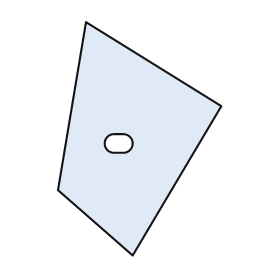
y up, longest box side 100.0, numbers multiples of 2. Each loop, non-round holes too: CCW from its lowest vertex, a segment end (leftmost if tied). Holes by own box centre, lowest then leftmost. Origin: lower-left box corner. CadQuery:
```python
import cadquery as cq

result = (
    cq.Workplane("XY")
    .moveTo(32.0, 0.0)
    .lineTo(70.0, 64.0)
    .lineTo(12.0, 100.0)
    .lineTo(0.0, 28.0)
    .close()
    .moveTo(24.0, 44.0)
    .lineTo(28.0, 44.0)
    .threePointArc((32.0, 48.0), (28.0, 52.0))
    .lineTo(24.0, 52.0)
    .threePointArc((20.0, 48.0), (24.0, 44.0))
    .close()
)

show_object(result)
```